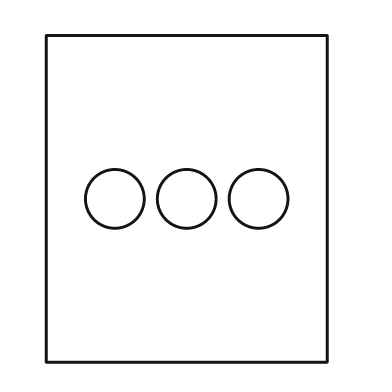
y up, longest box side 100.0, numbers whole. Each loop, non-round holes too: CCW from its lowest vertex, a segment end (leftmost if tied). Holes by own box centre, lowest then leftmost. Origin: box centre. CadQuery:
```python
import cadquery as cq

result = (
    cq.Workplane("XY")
    .moveTo(-43.0, -50.0)
    .lineTo(43.0, -50.0)
    .lineTo(43.0, 50.0)
    .lineTo(-43.0, 50.0)
    .close()
    .moveTo(-22.0, 0.0)
    .circle(9.0)
    .moveTo(0.0, 0.0)
    .circle(9.0)
    .moveTo(22.0, 0.0)
    .circle(9.0)
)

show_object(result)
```